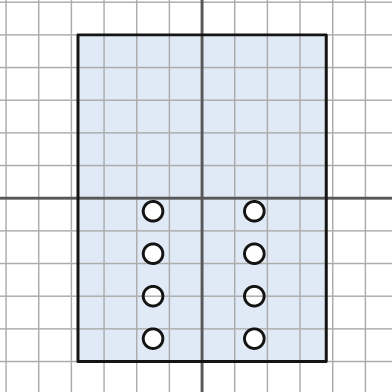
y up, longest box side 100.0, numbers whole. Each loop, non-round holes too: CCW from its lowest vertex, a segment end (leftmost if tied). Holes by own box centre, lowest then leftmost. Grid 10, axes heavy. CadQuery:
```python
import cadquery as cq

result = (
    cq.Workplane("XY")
    .moveTo(-38.0, -50.0)
    .lineTo(38.0, -50.0)
    .lineTo(38.0, 50.0)
    .lineTo(-38.0, 50.0)
    .close()
    .moveTo(-15.0, -43.0)
    .circle(3.0)
    .moveTo(16.0, -43.0)
    .circle(3.0)
    .moveTo(-15.0, -30.0)
    .circle(3.0)
    .moveTo(16.0, -30.0)
    .circle(3.0)
    .moveTo(-15.0, -17.0)
    .circle(3.0)
    .moveTo(16.0, -17.0)
    .circle(3.0)
    .moveTo(-15.0, -4.0)
    .circle(3.0)
    .moveTo(16.0, -4.0)
    .circle(3.0)
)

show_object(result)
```